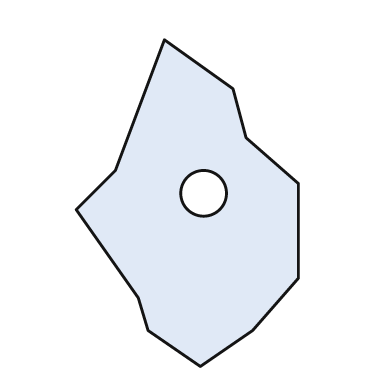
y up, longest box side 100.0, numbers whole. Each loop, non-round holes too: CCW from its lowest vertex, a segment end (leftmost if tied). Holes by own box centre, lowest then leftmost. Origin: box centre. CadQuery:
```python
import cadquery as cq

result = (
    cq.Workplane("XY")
    .moveTo(4.0, -50.0)
    .lineTo(20.0, -39.0)
    .lineTo(34.0, -23.0)
    .lineTo(34.0, 6.0)
    .lineTo(18.0, 20.0)
    .lineTo(14.0, 35.0)
    .lineTo(-7.0, 50.0)
    .lineTo(-22.0, 10.0)
    .lineTo(-34.0, -2.0)
    .lineTo(-15.0, -29.0)
    .lineTo(-12.0, -39.0)
    .close()
    .moveTo(5.0, 3.0)
    .circle(7.0)
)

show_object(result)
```